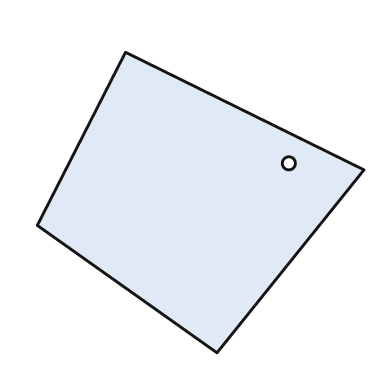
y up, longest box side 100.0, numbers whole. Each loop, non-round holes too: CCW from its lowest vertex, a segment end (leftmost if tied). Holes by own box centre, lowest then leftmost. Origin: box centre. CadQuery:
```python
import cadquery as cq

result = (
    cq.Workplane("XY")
    .moveTo(5.0, -46.0)
    .lineTo(50.0, 10.0)
    .lineTo(-23.0, 46.0)
    .lineTo(-50.0, -7.0)
    .close()
    .moveTo(27.0, 12.0)
    .circle(2.0)
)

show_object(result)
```